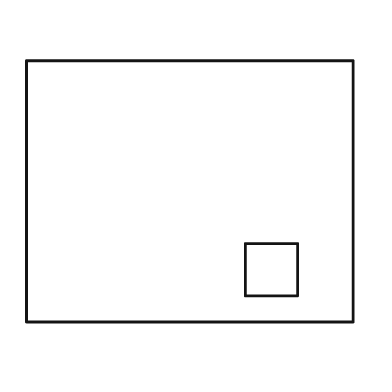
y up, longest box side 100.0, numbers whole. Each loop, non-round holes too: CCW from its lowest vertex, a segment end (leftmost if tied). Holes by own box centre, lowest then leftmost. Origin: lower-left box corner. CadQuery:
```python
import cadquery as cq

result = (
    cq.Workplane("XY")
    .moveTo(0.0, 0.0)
    .lineTo(100.0, 0.0)
    .lineTo(100.0, 80.0)
    .lineTo(0.0, 80.0)
    .close()
    .moveTo(67.0, 8.0)
    .lineTo(83.0, 8.0)
    .lineTo(83.0, 24.0)
    .lineTo(67.0, 24.0)
    .close()
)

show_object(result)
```